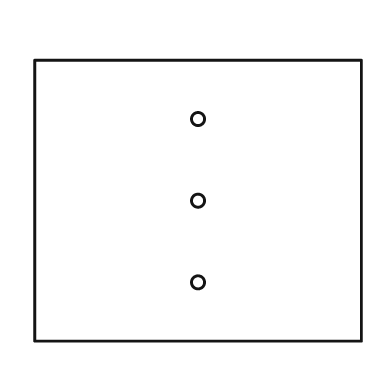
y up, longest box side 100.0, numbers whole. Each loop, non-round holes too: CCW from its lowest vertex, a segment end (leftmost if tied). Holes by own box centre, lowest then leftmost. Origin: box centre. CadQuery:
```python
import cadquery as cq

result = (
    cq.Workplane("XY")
    .moveTo(-50.0, -43.0)
    .lineTo(50.0, -43.0)
    .lineTo(50.0, 43.0)
    .lineTo(-50.0, 43.0)
    .close()
    .moveTo(0.0, -25.0)
    .circle(2.0)
    .moveTo(0.0, 0.0)
    .circle(2.0)
    .moveTo(0.0, 25.0)
    .circle(2.0)
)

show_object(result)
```